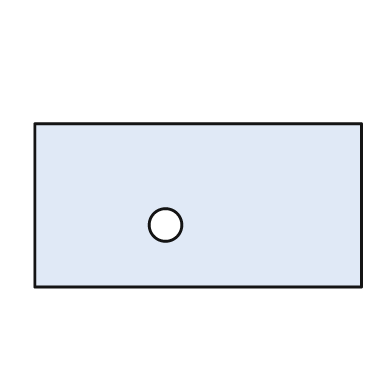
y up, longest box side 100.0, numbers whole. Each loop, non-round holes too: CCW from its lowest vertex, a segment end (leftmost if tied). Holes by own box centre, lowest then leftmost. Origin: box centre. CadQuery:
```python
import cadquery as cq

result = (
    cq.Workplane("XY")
    .moveTo(-50.0, -25.0)
    .lineTo(50.0, -25.0)
    .lineTo(50.0, 25.0)
    .lineTo(-50.0, 25.0)
    .close()
    .moveTo(-10.0, -6.0)
    .circle(5.0)
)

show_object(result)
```